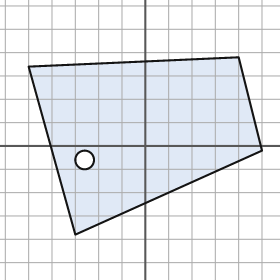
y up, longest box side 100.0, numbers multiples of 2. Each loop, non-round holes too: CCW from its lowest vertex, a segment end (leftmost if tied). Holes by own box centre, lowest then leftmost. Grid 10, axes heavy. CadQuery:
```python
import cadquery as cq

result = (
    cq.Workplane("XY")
    .moveTo(-30.0, -38.0)
    .lineTo(50.0, -2.0)
    .lineTo(40.0, 38.0)
    .lineTo(-50.0, 34.0)
    .close()
    .moveTo(-26.0, -6.0)
    .circle(4.0)
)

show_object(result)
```